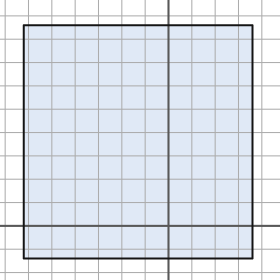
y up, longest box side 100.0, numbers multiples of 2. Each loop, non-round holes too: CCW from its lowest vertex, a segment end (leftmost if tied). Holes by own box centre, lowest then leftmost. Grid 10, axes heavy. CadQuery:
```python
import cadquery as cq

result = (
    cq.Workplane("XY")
    .moveTo(-62.0, -14.0)
    .lineTo(36.0, -14.0)
    .lineTo(36.0, 86.0)
    .lineTo(-62.0, 86.0)
    .close()
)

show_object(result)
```